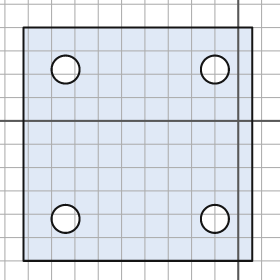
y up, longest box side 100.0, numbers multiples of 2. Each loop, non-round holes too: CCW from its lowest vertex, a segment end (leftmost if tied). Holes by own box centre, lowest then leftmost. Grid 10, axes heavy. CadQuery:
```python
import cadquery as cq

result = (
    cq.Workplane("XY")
    .moveTo(-92.0, -60.0)
    .lineTo(6.0, -60.0)
    .lineTo(6.0, 40.0)
    .lineTo(-92.0, 40.0)
    .close()
    .moveTo(-74.0, -42.0)
    .circle(6.0)
    .moveTo(-10.0, -42.0)
    .circle(6.0)
    .moveTo(-74.0, 22.0)
    .circle(6.0)
    .moveTo(-10.0, 22.0)
    .circle(6.0)
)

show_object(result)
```